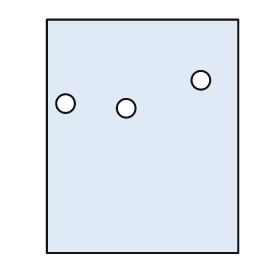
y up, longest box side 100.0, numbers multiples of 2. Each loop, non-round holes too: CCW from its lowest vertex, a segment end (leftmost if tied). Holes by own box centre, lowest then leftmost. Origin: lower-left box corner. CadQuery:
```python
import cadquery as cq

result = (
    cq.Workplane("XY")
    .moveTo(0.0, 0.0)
    .lineTo(82.0, 0.0)
    .lineTo(82.0, 100.0)
    .lineTo(0.0, 100.0)
    .close()
    .moveTo(34.0, 62.0)
    .circle(4.0)
    .moveTo(8.0, 64.0)
    .circle(4.0)
    .moveTo(66.0, 74.0)
    .circle(4.0)
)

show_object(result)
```